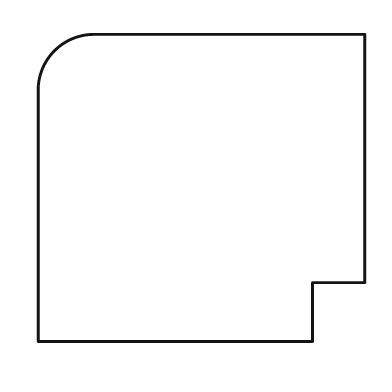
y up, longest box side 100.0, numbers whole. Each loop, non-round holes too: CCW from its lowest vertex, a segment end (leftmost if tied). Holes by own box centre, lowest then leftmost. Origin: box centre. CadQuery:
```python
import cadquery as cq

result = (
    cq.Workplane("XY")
    .moveTo(-50.0, -47.0)
    .lineTo(34.0, -47.0)
    .lineTo(34.0, -29.0)
    .lineTo(50.0, -29.0)
    .lineTo(50.0, 47.0)
    .lineTo(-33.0, 47.0)
    .threePointArc((-45.0, 42.0), (-50.0, 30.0))
    .close()
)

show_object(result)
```